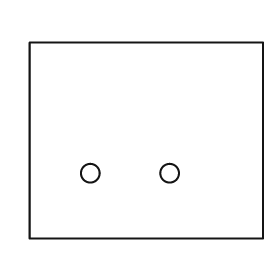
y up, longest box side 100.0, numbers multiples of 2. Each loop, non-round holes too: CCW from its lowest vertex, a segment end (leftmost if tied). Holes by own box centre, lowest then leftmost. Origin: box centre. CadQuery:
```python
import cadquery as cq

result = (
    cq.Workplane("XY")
    .moveTo(-50.0, -42.0)
    .lineTo(50.0, -42.0)
    .lineTo(50.0, 42.0)
    .lineTo(-50.0, 42.0)
    .close()
    .moveTo(-24.0, -14.0)
    .circle(4.0)
    .moveTo(10.0, -14.0)
    .circle(4.0)
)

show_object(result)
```